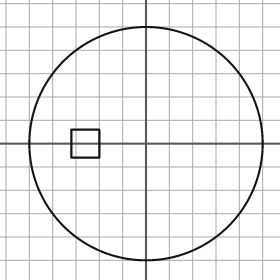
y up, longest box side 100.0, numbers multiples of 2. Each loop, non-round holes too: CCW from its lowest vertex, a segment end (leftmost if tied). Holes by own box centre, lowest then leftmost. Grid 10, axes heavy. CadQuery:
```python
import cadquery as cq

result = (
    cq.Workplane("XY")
    .moveTo(0.0, 0.0)
    .circle(50.0)
    .moveTo(-32.0, -6.0)
    .lineTo(-20.0, -6.0)
    .lineTo(-20.0, 6.0)
    .lineTo(-32.0, 6.0)
    .close()
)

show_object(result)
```